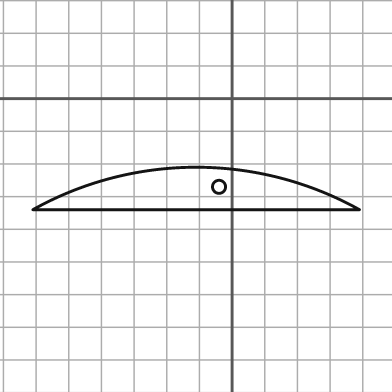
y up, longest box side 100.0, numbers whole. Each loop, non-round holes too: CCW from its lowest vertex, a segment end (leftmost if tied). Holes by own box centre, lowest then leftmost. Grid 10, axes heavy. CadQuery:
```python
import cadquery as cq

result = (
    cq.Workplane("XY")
    .moveTo(-61.0, -34.0)
    .lineTo(39.0, -34.0)
    .threePointArc((-11.0, -21.0), (-61.0, -34.0))
    .close()
    .moveTo(-4.0, -27.0)
    .circle(2.0)
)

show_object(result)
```